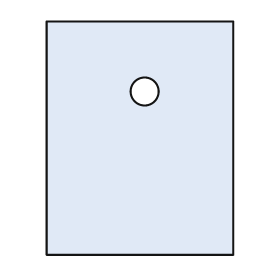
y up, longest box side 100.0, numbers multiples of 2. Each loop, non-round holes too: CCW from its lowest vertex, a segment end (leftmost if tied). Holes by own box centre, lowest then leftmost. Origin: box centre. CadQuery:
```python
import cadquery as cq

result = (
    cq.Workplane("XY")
    .moveTo(-40.0, -50.0)
    .lineTo(40.0, -50.0)
    .lineTo(40.0, 50.0)
    .lineTo(-40.0, 50.0)
    .close()
    .moveTo(2.0, 20.0)
    .circle(6.0)
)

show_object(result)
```